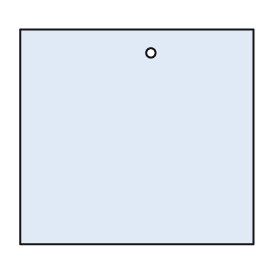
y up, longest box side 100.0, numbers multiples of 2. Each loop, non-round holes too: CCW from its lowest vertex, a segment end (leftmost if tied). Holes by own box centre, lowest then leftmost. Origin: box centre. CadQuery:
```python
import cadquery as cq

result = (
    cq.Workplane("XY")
    .moveTo(-50.0, -46.0)
    .lineTo(50.0, -46.0)
    .lineTo(50.0, 46.0)
    .lineTo(-50.0, 46.0)
    .close()
    .moveTo(6.0, 36.0)
    .circle(2.0)
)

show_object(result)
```